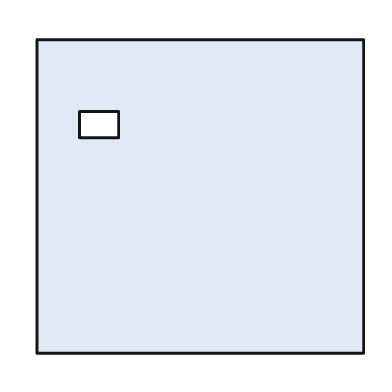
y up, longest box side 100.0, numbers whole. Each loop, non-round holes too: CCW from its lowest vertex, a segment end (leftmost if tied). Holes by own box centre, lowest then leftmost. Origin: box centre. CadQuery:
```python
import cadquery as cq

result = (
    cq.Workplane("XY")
    .moveTo(-50.0, -48.0)
    .lineTo(50.0, -48.0)
    .lineTo(50.0, 48.0)
    .lineTo(-50.0, 48.0)
    .close()
    .moveTo(-37.0, 18.0)
    .lineTo(-25.0, 18.0)
    .lineTo(-25.0, 26.0)
    .lineTo(-37.0, 26.0)
    .close()
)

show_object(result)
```